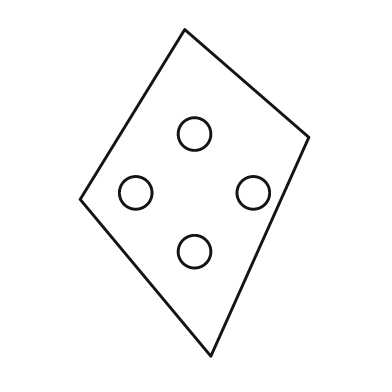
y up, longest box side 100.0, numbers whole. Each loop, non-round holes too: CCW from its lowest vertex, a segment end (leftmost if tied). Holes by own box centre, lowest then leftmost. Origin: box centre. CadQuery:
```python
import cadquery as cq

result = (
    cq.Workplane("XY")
    .moveTo(5.0, -50.0)
    .lineTo(35.0, 17.0)
    .lineTo(-3.0, 50.0)
    .lineTo(-35.0, -2.0)
    .close()
    .moveTo(0.0, -18.0)
    .circle(5.0)
    .moveTo(-18.0, 0.0)
    .circle(5.0)
    .moveTo(18.0, 0.0)
    .circle(5.0)
    .moveTo(0.0, 18.0)
    .circle(5.0)
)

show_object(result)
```